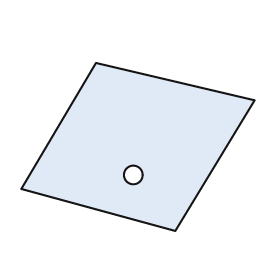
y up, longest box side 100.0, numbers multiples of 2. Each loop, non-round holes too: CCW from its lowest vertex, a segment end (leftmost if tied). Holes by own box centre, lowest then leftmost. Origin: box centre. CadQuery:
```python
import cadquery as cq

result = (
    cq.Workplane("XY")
    .moveTo(16.0, -36.0)
    .lineTo(50.0, 20.0)
    .lineTo(-18.0, 36.0)
    .lineTo(-50.0, -18.0)
    .close()
    .moveTo(-2.0, -12.0)
    .circle(4.0)
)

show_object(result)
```